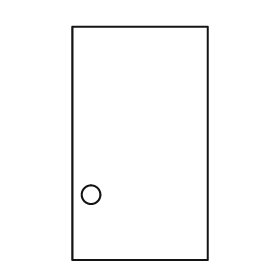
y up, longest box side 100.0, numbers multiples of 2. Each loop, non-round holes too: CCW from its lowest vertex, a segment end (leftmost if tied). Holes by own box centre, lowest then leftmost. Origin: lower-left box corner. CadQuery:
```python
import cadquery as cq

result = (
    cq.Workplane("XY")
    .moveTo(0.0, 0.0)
    .lineTo(58.0, 0.0)
    .lineTo(58.0, 100.0)
    .lineTo(0.0, 100.0)
    .close()
    .moveTo(8.0, 28.0)
    .circle(4.0)
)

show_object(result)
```